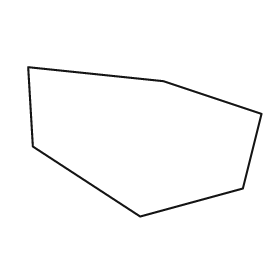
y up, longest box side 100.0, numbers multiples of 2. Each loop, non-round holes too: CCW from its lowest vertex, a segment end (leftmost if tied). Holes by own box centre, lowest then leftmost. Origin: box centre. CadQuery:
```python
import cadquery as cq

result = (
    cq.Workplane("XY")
    .moveTo(-2.0, -32.0)
    .lineTo(42.0, -20.0)
    .lineTo(50.0, 12.0)
    .lineTo(8.0, 26.0)
    .lineTo(-50.0, 32.0)
    .lineTo(-48.0, -2.0)
    .close()
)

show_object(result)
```